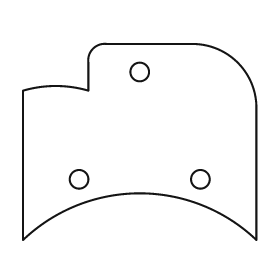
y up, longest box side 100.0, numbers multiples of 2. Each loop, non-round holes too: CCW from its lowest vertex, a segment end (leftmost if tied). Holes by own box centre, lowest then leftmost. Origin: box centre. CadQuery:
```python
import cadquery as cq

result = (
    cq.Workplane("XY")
    .moveTo(-50.0, -42.0)
    .threePointArc((0.0, -22.0), (50.0, -42.0))
    .lineTo(50.0, 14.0)
    .threePointArc((42.0, 34.0), (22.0, 42.0))
    .lineTo(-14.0, 42.0)
    .threePointArc((-20.0, 40.0), (-22.0, 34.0))
    .lineTo(-22.0, 22.0)
    .threePointArc((-36.0, 24.0), (-50.0, 22.0))
    .close()
    .moveTo(-26.0, -16.0)
    .circle(4.0)
    .moveTo(26.0, -16.0)
    .circle(4.0)
    .moveTo(0.0, 30.0)
    .circle(4.0)
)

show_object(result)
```